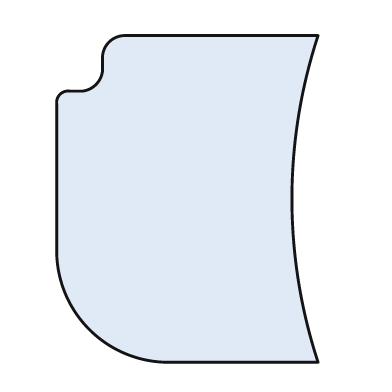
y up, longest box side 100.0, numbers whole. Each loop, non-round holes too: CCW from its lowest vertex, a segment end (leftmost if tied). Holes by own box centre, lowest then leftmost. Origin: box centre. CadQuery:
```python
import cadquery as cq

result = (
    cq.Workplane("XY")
    .moveTo(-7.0, -50.0)
    .lineTo(40.0, -50.0)
    .threePointArc((32.0, 0.0), (40.0, 50.0))
    .lineTo(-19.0, 50.0)
    .threePointArc((-24.0, 48.0), (-26.0, 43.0))
    .lineTo(-26.0, 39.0)
    .threePointArc((-28.0, 35.0), (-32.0, 33.0))
    .lineTo(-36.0, 33.0)
    .threePointArc((-39.0, 32.0), (-40.0, 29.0))
    .lineTo(-40.0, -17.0)
    .threePointArc((-30.0, -40.0), (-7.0, -50.0))
    .close()
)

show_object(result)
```